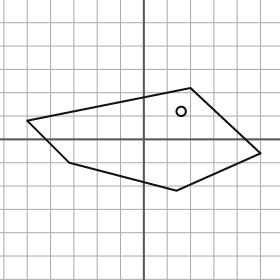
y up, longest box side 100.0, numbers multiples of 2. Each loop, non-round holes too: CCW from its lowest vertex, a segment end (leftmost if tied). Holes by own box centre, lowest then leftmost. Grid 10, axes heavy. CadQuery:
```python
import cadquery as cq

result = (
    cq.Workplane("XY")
    .moveTo(14.0, -22.0)
    .lineTo(50.0, -6.0)
    .lineTo(20.0, 22.0)
    .lineTo(-50.0, 8.0)
    .lineTo(-32.0, -10.0)
    .close()
    .moveTo(16.0, 12.0)
    .circle(2.0)
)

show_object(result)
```